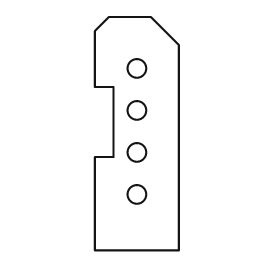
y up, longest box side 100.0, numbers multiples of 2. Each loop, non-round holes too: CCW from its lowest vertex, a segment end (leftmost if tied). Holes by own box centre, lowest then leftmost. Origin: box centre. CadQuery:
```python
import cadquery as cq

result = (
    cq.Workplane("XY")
    .moveTo(-18.0, -50.0)
    .lineTo(18.0, -50.0)
    .lineTo(18.0, 38.0)
    .lineTo(6.0, 50.0)
    .lineTo(-12.0, 50.0)
    .lineTo(-18.0, 44.0)
    .lineTo(-18.0, 20.0)
    .lineTo(-10.0, 20.0)
    .lineTo(-10.0, -10.0)
    .lineTo(-18.0, -10.0)
    .close()
    .moveTo(0.0, -26.0)
    .circle(4.0)
    .moveTo(0.0, -8.0)
    .circle(4.0)
    .moveTo(0.0, 10.0)
    .circle(4.0)
    .moveTo(0.0, 28.0)
    .circle(4.0)
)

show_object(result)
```